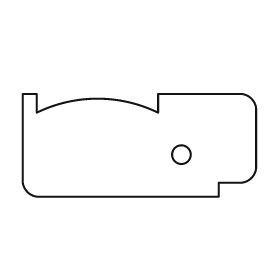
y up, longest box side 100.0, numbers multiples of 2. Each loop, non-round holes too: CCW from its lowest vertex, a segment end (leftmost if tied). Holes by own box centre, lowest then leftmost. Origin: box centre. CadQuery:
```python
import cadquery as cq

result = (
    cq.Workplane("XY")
    .moveTo(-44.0, -22.0)
    .lineTo(34.0, -22.0)
    .lineTo(34.0, -16.0)
    .lineTo(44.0, -16.0)
    .threePointArc((48.0, -14.0), (50.0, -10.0))
    .lineTo(50.0, 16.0)
    .threePointArc((48.0, 20.0), (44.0, 22.0))
    .lineTo(8.0, 22.0)
    .lineTo(8.0, 14.0)
    .threePointArc((-18.0, 20.0), (-44.0, 14.0))
    .lineTo(-44.0, 22.0)
    .lineTo(-50.0, 22.0)
    .lineTo(-50.0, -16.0)
    .threePointArc((-48.0, -20.0), (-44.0, -22.0))
    .close()
    .moveTo(18.0, -4.0)
    .circle(4.0)
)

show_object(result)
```